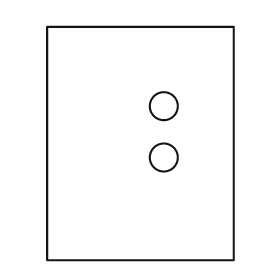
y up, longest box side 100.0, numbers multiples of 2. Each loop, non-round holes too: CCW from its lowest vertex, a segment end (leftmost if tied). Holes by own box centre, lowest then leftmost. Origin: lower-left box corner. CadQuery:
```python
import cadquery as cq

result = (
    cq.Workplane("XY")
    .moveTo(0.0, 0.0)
    .lineTo(80.0, 0.0)
    .lineTo(80.0, 100.0)
    .lineTo(0.0, 100.0)
    .close()
    .moveTo(50.0, 44.0)
    .circle(6.0)
    .moveTo(50.0, 66.0)
    .circle(6.0)
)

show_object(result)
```